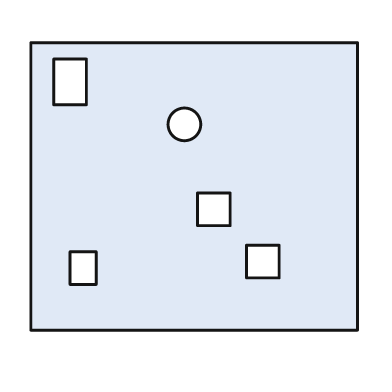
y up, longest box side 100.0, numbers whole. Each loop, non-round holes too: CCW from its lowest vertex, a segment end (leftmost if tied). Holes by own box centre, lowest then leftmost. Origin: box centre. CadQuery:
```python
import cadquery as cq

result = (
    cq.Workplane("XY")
    .moveTo(-50.0, -44.0)
    .lineTo(50.0, -44.0)
    .lineTo(50.0, 44.0)
    .lineTo(-50.0, 44.0)
    .close()
    .moveTo(-38.0, -30.0)
    .lineTo(-30.0, -30.0)
    .lineTo(-30.0, -20.0)
    .lineTo(-38.0, -20.0)
    .close()
    .moveTo(16.0, -28.0)
    .lineTo(26.0, -28.0)
    .lineTo(26.0, -18.0)
    .lineTo(16.0, -18.0)
    .close()
    .moveTo(1.0, -12.0)
    .lineTo(11.0, -12.0)
    .lineTo(11.0, -2.0)
    .lineTo(1.0, -2.0)
    .close()
    .moveTo(-3.0, 19.0)
    .circle(5.0)
    .moveTo(-43.0, 25.0)
    .lineTo(-33.0, 25.0)
    .lineTo(-33.0, 39.0)
    .lineTo(-43.0, 39.0)
    .close()
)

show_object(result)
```